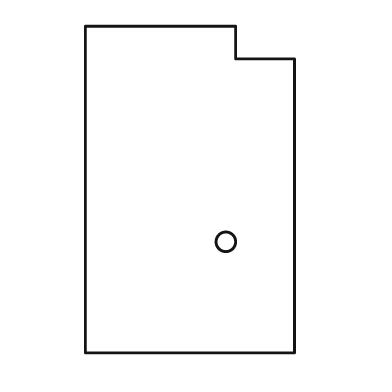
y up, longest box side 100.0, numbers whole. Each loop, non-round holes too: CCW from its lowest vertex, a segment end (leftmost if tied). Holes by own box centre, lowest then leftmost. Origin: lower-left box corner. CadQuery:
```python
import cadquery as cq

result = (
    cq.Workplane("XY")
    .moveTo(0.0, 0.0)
    .lineTo(64.0, 0.0)
    .lineTo(64.0, 90.0)
    .lineTo(46.0, 90.0)
    .lineTo(46.0, 100.0)
    .lineTo(0.0, 100.0)
    .close()
    .moveTo(43.0, 34.0)
    .circle(3.0)
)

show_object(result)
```